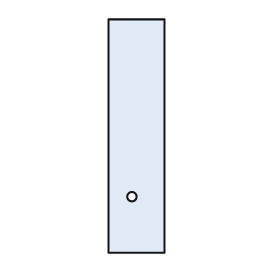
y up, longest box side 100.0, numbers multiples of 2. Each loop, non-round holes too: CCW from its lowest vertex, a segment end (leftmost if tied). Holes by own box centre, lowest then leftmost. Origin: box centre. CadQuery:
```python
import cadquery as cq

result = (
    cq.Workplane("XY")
    .moveTo(-12.0, -50.0)
    .lineTo(12.0, -50.0)
    .lineTo(12.0, 50.0)
    .lineTo(-12.0, 50.0)
    .close()
    .moveTo(-2.0, -26.0)
    .circle(2.0)
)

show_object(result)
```